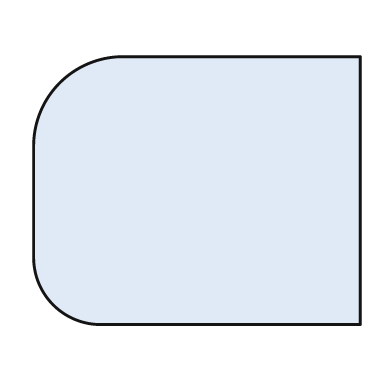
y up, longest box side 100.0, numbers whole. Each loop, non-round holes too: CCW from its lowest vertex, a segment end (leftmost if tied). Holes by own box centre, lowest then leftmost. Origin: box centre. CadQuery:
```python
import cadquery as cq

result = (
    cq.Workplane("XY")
    .moveTo(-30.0, -41.0)
    .lineTo(50.0, -41.0)
    .lineTo(50.0, 41.0)
    .lineTo(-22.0, 41.0)
    .threePointArc((-42.0, 33.0), (-50.0, 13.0))
    .lineTo(-50.0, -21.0)
    .threePointArc((-44.0, -35.0), (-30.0, -41.0))
    .close()
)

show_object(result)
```